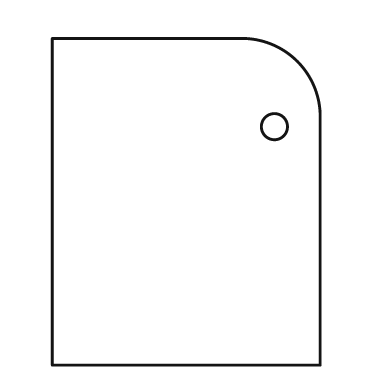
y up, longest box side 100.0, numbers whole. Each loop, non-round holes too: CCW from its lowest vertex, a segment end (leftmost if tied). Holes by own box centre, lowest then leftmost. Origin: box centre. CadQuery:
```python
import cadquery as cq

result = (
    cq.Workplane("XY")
    .moveTo(-41.0, -50.0)
    .lineTo(41.0, -50.0)
    .lineTo(41.0, 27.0)
    .threePointArc((34.0, 43.0), (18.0, 50.0))
    .lineTo(-41.0, 50.0)
    .close()
    .moveTo(27.0, 23.0)
    .circle(4.0)
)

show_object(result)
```